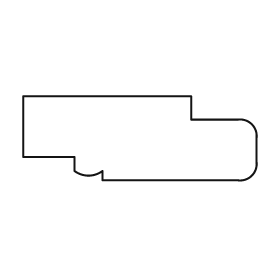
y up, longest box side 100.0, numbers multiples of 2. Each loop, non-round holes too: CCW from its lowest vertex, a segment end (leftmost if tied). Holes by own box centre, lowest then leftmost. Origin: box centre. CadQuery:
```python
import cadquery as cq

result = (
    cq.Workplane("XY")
    .moveTo(-16.0, -18.0)
    .lineTo(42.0, -18.0)
    .threePointArc((48.0, -16.0), (50.0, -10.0))
    .lineTo(50.0, 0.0)
    .threePointArc((48.0, 6.0), (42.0, 8.0))
    .lineTo(22.0, 8.0)
    .lineTo(22.0, 18.0)
    .lineTo(-50.0, 18.0)
    .lineTo(-50.0, -8.0)
    .lineTo(-28.0, -8.0)
    .lineTo(-28.0, -14.0)
    .threePointArc((-22.0, -16.0), (-16.0, -14.0))
    .close()
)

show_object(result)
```